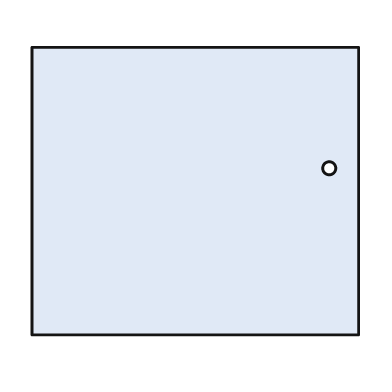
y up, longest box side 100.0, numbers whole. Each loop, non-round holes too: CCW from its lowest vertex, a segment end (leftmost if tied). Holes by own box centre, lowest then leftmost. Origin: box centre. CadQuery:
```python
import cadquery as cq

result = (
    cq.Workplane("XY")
    .moveTo(-50.0, -44.0)
    .lineTo(50.0, -44.0)
    .lineTo(50.0, 44.0)
    .lineTo(-50.0, 44.0)
    .close()
    .moveTo(41.0, 7.0)
    .circle(2.0)
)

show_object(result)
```